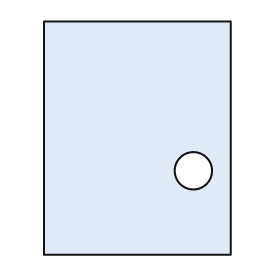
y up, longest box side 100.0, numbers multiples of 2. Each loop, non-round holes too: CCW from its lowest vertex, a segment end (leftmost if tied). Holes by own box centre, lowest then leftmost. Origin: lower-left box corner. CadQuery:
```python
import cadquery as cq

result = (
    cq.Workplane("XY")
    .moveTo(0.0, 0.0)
    .lineTo(80.0, 0.0)
    .lineTo(80.0, 100.0)
    .lineTo(0.0, 100.0)
    .close()
    .moveTo(64.0, 36.0)
    .circle(8.0)
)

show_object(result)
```